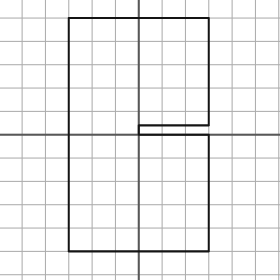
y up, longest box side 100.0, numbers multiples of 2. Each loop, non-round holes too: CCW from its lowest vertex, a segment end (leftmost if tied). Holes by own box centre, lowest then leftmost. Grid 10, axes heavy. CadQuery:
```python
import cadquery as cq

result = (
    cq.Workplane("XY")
    .moveTo(-30.0, -50.0)
    .lineTo(30.0, -50.0)
    .lineTo(30.0, 0.0)
    .lineTo(0.0, 0.0)
    .lineTo(0.0, 4.0)
    .lineTo(30.0, 4.0)
    .lineTo(30.0, 50.0)
    .lineTo(-30.0, 50.0)
    .close()
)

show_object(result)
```